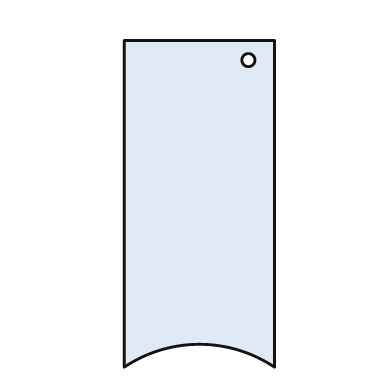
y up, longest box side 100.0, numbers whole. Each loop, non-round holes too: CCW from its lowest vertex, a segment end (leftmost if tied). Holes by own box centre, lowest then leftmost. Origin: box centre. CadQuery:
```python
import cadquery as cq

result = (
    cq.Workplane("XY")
    .moveTo(-23.0, -50.0)
    .threePointArc((0.0, -43.0), (23.0, -50.0))
    .lineTo(23.0, 50.0)
    .lineTo(-23.0, 50.0)
    .close()
    .moveTo(15.0, 44.0)
    .circle(2.0)
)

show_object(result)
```